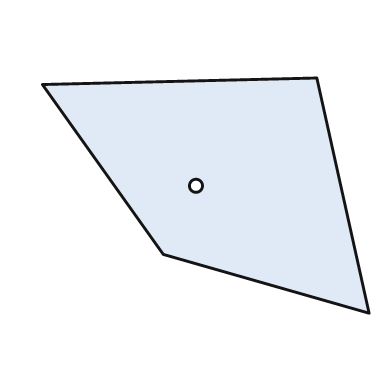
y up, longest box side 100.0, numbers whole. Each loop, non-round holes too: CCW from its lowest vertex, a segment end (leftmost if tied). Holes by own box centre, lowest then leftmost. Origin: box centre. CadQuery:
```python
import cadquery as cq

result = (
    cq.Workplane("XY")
    .moveTo(50.0, -36.0)
    .lineTo(34.0, 36.0)
    .lineTo(-50.0, 34.0)
    .lineTo(-13.0, -18.0)
    .close()
    .moveTo(-3.0, 3.0)
    .circle(2.0)
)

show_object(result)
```